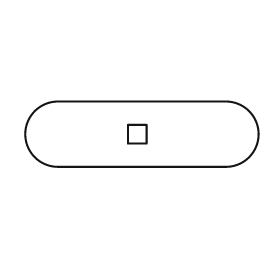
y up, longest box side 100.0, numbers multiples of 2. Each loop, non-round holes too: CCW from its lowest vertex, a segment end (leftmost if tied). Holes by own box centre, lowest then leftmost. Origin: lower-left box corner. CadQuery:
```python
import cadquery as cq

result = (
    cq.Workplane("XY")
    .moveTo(14.0, 0.0)
    .lineTo(86.0, 0.0)
    .threePointArc((100.0, 14.0), (86.0, 28.0))
    .lineTo(14.0, 28.0)
    .threePointArc((0.0, 14.0), (14.0, 0.0))
    .close()
    .moveTo(44.0, 10.0)
    .lineTo(52.0, 10.0)
    .lineTo(52.0, 18.0)
    .lineTo(44.0, 18.0)
    .close()
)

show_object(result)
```